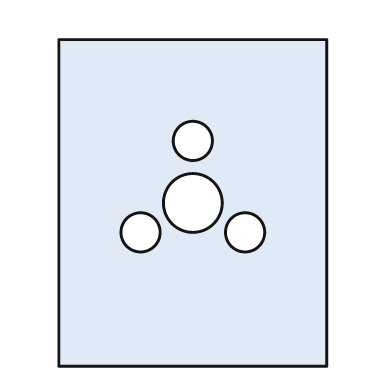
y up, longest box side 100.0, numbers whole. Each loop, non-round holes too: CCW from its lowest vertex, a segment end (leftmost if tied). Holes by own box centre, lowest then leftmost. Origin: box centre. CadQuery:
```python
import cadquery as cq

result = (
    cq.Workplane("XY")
    .moveTo(-41.0, -50.0)
    .lineTo(41.0, -50.0)
    .lineTo(41.0, 50.0)
    .lineTo(-41.0, 50.0)
    .close()
    .moveTo(-16.0, -9.0)
    .circle(6.0)
    .moveTo(16.0, -9.0)
    .circle(6.0)
    .moveTo(0.0, 0.0)
    .circle(9.0)
    .moveTo(0.0, 19.0)
    .circle(6.0)
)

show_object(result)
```